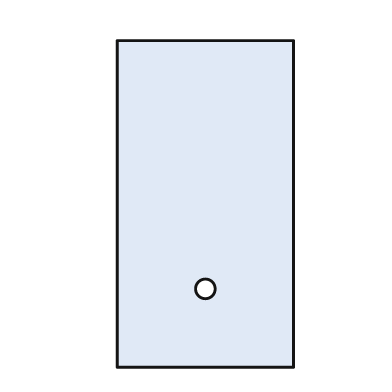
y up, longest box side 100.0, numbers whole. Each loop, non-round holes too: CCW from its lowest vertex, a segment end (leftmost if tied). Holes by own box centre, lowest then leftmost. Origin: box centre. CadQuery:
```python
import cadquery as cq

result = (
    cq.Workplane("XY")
    .moveTo(-27.0, -50.0)
    .lineTo(27.0, -50.0)
    .lineTo(27.0, 50.0)
    .lineTo(-27.0, 50.0)
    .close()
    .moveTo(0.0, -26.0)
    .circle(3.0)
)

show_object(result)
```